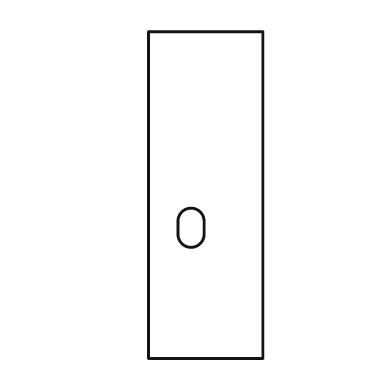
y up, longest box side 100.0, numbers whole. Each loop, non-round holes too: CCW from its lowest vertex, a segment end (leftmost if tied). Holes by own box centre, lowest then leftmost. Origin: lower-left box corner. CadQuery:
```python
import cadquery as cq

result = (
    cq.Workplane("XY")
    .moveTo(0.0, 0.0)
    .lineTo(35.0, 0.0)
    .lineTo(35.0, 100.0)
    .lineTo(0.0, 100.0)
    .close()
    .moveTo(9.0, 38.0)
    .threePointArc((13.0, 34.0), (17.0, 38.0))
    .lineTo(17.0, 42.0)
    .threePointArc((13.0, 46.0), (9.0, 42.0))
    .close()
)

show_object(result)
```